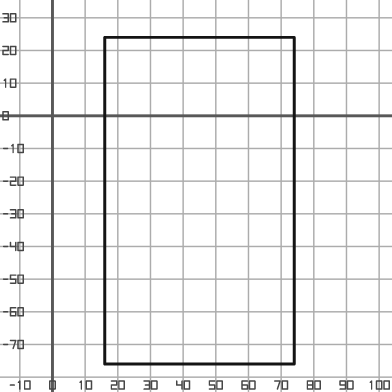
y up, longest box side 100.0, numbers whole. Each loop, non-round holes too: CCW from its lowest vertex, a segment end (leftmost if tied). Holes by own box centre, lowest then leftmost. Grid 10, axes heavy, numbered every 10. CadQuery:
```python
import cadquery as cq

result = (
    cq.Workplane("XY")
    .moveTo(16.0, -76.0)
    .lineTo(74.0, -76.0)
    .lineTo(74.0, 24.0)
    .lineTo(16.0, 24.0)
    .close()
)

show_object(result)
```